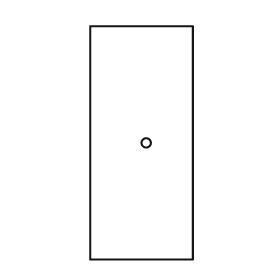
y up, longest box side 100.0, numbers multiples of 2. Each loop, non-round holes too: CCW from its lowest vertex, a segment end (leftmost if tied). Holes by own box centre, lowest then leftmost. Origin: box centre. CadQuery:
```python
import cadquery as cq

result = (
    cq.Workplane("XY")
    .moveTo(-22.0, -50.0)
    .lineTo(22.0, -50.0)
    .lineTo(22.0, 50.0)
    .lineTo(-22.0, 50.0)
    .close()
    .moveTo(2.0, 0.0)
    .circle(2.0)
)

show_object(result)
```